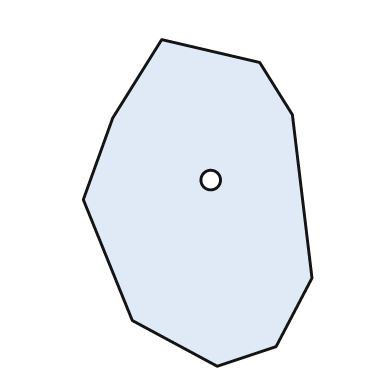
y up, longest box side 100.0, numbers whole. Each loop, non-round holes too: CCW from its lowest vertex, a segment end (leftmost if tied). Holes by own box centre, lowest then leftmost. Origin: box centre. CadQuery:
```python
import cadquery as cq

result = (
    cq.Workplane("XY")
    .moveTo(6.0, -50.0)
    .lineTo(24.0, -44.0)
    .lineTo(35.0, -23.0)
    .lineTo(29.0, 27.0)
    .lineTo(19.0, 43.0)
    .lineTo(-11.0, 50.0)
    .lineTo(-26.0, 26.0)
    .lineTo(-35.0, 1.0)
    .lineTo(-20.0, -36.0)
    .close()
    .moveTo(4.0, 7.0)
    .circle(3.0)
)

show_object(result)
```